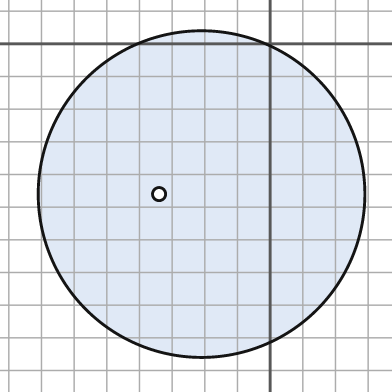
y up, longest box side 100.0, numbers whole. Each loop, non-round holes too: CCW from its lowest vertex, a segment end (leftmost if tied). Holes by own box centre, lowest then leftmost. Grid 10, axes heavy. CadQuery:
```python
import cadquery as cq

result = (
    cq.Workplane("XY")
    .moveTo(-21.0, -46.0)
    .circle(50.0)
    .moveTo(-34.0, -46.0)
    .circle(2.0)
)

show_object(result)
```